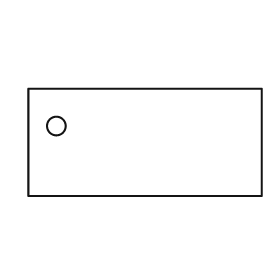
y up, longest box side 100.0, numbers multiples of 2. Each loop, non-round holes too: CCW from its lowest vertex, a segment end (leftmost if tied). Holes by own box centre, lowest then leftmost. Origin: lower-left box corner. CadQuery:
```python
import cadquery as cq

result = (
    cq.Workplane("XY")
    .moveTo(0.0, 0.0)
    .lineTo(100.0, 0.0)
    .lineTo(100.0, 46.0)
    .lineTo(0.0, 46.0)
    .close()
    .moveTo(12.0, 30.0)
    .circle(4.0)
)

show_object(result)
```